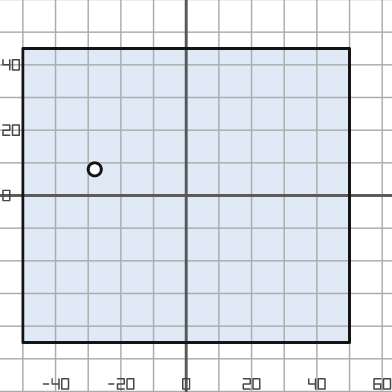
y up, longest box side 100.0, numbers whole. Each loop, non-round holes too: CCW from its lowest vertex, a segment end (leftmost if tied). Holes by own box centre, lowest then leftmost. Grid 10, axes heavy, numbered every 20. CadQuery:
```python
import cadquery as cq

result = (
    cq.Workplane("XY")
    .moveTo(-50.0, -45.0)
    .lineTo(50.0, -45.0)
    .lineTo(50.0, 45.0)
    .lineTo(-50.0, 45.0)
    .close()
    .moveTo(-28.0, 8.0)
    .circle(2.0)
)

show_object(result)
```